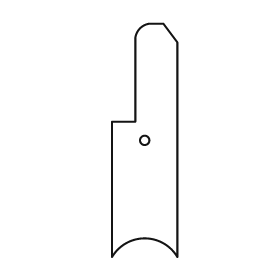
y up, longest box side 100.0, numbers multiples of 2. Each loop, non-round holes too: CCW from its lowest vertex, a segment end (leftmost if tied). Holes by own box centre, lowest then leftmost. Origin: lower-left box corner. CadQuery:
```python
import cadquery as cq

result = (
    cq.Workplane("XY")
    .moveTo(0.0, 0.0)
    .threePointArc((14.0, 8.0), (28.0, 0.0))
    .lineTo(28.0, 92.0)
    .lineTo(22.0, 100.0)
    .lineTo(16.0, 100.0)
    .threePointArc((12.0, 98.0), (10.0, 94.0))
    .lineTo(10.0, 58.0)
    .lineTo(0.0, 58.0)
    .close()
    .moveTo(14.0, 50.0)
    .circle(2.0)
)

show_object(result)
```